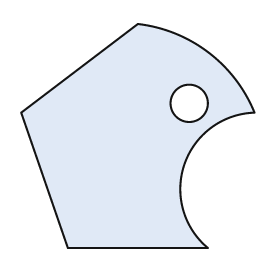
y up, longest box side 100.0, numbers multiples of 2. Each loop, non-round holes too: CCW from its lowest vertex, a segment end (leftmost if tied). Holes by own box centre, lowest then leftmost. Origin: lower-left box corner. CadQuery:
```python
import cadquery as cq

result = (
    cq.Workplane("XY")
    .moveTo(20.0, 0.0)
    .lineTo(80.0, 0.0)
    .threePointArc((70.0, 36.0), (100.0, 58.0))
    .threePointArc((80.0, 84.0), (50.0, 96.0))
    .lineTo(0.0, 58.0)
    .close()
    .moveTo(72.0, 62.0)
    .circle(8.0)
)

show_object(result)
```